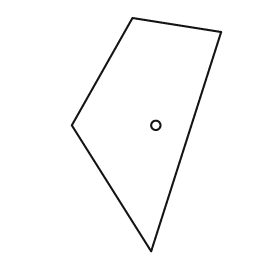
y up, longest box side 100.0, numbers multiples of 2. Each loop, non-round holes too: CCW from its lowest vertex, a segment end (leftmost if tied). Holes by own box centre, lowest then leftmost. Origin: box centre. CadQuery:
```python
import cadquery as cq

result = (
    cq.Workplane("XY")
    .moveTo(2.0, -50.0)
    .lineTo(32.0, 44.0)
    .lineTo(-6.0, 50.0)
    .lineTo(-32.0, 4.0)
    .close()
    .moveTo(4.0, 4.0)
    .circle(2.0)
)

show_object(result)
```